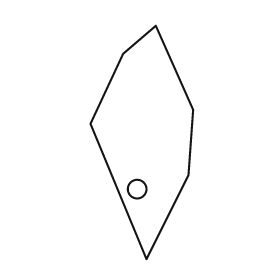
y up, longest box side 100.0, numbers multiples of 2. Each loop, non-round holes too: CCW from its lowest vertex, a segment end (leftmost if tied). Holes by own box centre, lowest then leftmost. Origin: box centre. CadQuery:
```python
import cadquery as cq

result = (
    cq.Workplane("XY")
    .moveTo(2.0, -50.0)
    .lineTo(20.0, -14.0)
    .lineTo(22.0, 14.0)
    .lineTo(6.0, 50.0)
    .lineTo(-8.0, 38.0)
    .lineTo(-22.0, 8.0)
    .close()
    .moveTo(-2.0, -20.0)
    .circle(4.0)
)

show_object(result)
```